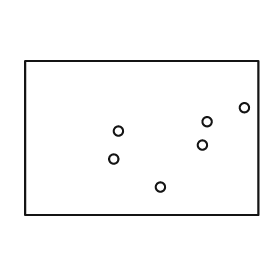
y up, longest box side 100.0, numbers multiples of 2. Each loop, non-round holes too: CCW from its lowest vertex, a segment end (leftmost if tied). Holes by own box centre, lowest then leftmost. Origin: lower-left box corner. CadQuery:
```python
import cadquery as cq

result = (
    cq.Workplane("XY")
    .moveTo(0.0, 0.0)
    .lineTo(100.0, 0.0)
    .lineTo(100.0, 66.0)
    .lineTo(0.0, 66.0)
    .close()
    .moveTo(58.0, 12.0)
    .circle(2.0)
    .moveTo(38.0, 24.0)
    .circle(2.0)
    .moveTo(76.0, 30.0)
    .circle(2.0)
    .moveTo(40.0, 36.0)
    .circle(2.0)
    .moveTo(78.0, 40.0)
    .circle(2.0)
    .moveTo(94.0, 46.0)
    .circle(2.0)
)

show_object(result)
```